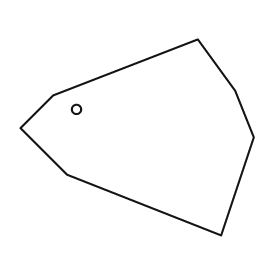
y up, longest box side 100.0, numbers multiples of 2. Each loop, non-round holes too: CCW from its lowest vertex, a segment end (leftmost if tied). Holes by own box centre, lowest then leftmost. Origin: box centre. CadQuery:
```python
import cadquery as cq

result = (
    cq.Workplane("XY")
    .moveTo(36.0, -42.0)
    .lineTo(50.0, 0.0)
    .lineTo(42.0, 20.0)
    .lineTo(26.0, 42.0)
    .lineTo(-36.0, 18.0)
    .lineTo(-50.0, 4.0)
    .lineTo(-30.0, -16.0)
    .close()
    .moveTo(-26.0, 12.0)
    .circle(2.0)
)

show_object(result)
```